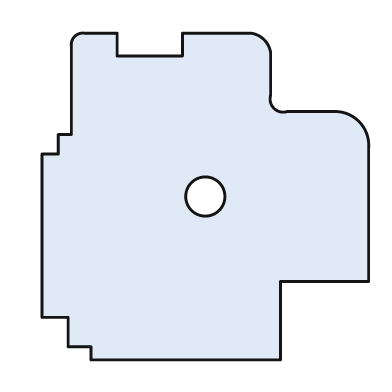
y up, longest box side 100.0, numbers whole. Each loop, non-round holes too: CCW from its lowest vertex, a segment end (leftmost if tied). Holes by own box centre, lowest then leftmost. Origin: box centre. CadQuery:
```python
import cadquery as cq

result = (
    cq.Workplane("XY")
    .moveTo(-35.0, -50.0)
    .lineTo(23.0, -50.0)
    .lineTo(23.0, -26.0)
    .lineTo(50.0, -26.0)
    .lineTo(50.0, 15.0)
    .threePointArc((47.0, 23.0), (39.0, 26.0))
    .lineTo(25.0, 26.0)
    .threePointArc((21.0, 27.0), (20.0, 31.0))
    .lineTo(20.0, 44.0)
    .threePointArc((18.0, 48.0), (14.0, 50.0))
    .lineTo(-7.0, 50.0)
    .lineTo(-7.0, 43.0)
    .lineTo(-27.0, 43.0)
    .lineTo(-27.0, 50.0)
    .lineTo(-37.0, 50.0)
    .threePointArc((-40.0, 49.0), (-41.0, 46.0))
    .lineTo(-41.0, 19.0)
    .lineTo(-45.0, 19.0)
    .lineTo(-45.0, 13.0)
    .lineTo(-50.0, 13.0)
    .lineTo(-50.0, -37.0)
    .lineTo(-42.0, -37.0)
    .lineTo(-42.0, -46.0)
    .lineTo(-35.0, -46.0)
    .close()
    .moveTo(0.0, 0.0)
    .circle(6.0)
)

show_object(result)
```